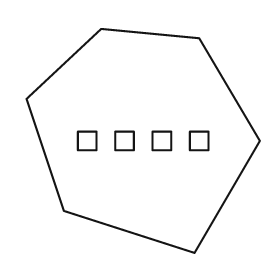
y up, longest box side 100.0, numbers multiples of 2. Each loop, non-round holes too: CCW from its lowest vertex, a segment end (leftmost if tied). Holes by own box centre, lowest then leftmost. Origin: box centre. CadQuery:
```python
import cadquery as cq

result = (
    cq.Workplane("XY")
    .moveTo(22.0, -48.0)
    .lineTo(50.0, 0.0)
    .lineTo(24.0, 44.0)
    .lineTo(-18.0, 48.0)
    .lineTo(-50.0, 18.0)
    .lineTo(-34.0, -30.0)
    .close()
    .moveTo(-28.0, -4.0)
    .lineTo(-20.0, -4.0)
    .lineTo(-20.0, 4.0)
    .lineTo(-28.0, 4.0)
    .close()
    .moveTo(-12.0, -4.0)
    .lineTo(-4.0, -4.0)
    .lineTo(-4.0, 4.0)
    .lineTo(-12.0, 4.0)
    .close()
    .moveTo(4.0, -4.0)
    .lineTo(12.0, -4.0)
    .lineTo(12.0, 4.0)
    .lineTo(4.0, 4.0)
    .close()
    .moveTo(20.0, -4.0)
    .lineTo(28.0, -4.0)
    .lineTo(28.0, 4.0)
    .lineTo(20.0, 4.0)
    .close()
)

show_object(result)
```